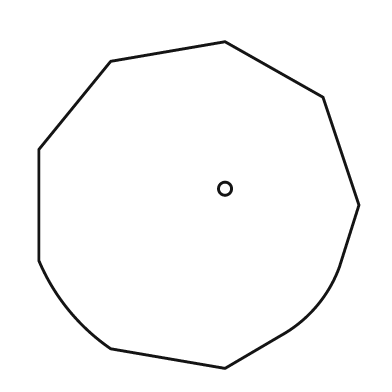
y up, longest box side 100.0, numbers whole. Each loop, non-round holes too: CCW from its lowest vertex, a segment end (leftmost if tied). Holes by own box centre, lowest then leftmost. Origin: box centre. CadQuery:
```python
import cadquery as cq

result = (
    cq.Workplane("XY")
    .moveTo(8.0, -50.0)
    .lineTo(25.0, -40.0)
    .threePointArc((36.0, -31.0), (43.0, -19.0))
    .lineTo(49.0, 0.0)
    .lineTo(38.0, 33.0)
    .lineTo(8.0, 50.0)
    .lineTo(-27.0, 44.0)
    .lineTo(-49.0, 17.0)
    .lineTo(-49.0, -17.0)
    .threePointArc((-40.0, -32.0), (-27.0, -44.0))
    .close()
    .moveTo(8.0, 5.0)
    .circle(2.0)
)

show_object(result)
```